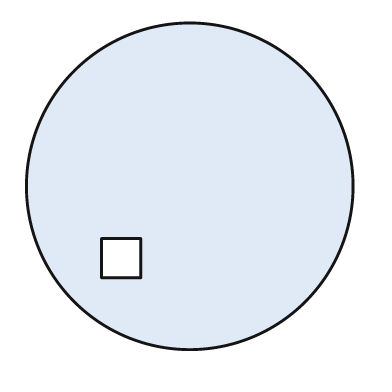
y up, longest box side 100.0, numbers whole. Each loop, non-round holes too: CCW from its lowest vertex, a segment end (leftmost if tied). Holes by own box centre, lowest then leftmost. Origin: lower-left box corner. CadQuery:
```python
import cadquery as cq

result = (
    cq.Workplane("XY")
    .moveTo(50.0, 50.0)
    .circle(50.0)
    .moveTo(23.0, 22.0)
    .lineTo(35.0, 22.0)
    .lineTo(35.0, 34.0)
    .lineTo(23.0, 34.0)
    .close()
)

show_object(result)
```